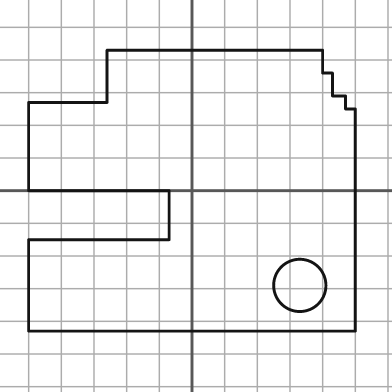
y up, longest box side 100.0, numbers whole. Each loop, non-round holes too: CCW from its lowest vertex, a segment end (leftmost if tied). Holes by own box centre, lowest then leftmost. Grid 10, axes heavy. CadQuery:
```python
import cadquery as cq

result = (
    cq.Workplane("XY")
    .moveTo(-50.0, -43.0)
    .lineTo(50.0, -43.0)
    .lineTo(50.0, 25.0)
    .lineTo(47.0, 25.0)
    .lineTo(47.0, 29.0)
    .lineTo(43.0, 29.0)
    .lineTo(43.0, 36.0)
    .lineTo(40.0, 36.0)
    .lineTo(40.0, 43.0)
    .lineTo(-26.0, 43.0)
    .lineTo(-26.0, 27.0)
    .lineTo(-50.0, 27.0)
    .lineTo(-50.0, 0.0)
    .lineTo(-7.0, 0.0)
    .lineTo(-7.0, -15.0)
    .lineTo(-50.0, -15.0)
    .close()
    .moveTo(33.0, -29.0)
    .circle(8.0)
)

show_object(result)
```